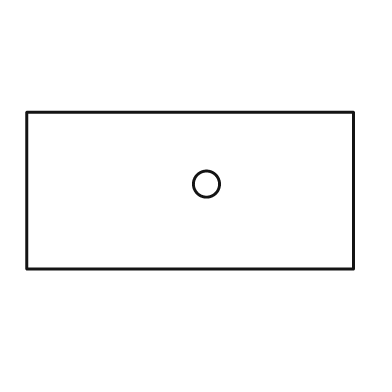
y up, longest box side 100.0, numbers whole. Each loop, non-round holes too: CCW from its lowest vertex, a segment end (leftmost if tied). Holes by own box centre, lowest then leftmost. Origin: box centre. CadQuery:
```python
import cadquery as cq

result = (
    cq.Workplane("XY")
    .moveTo(-50.0, -24.0)
    .lineTo(50.0, -24.0)
    .lineTo(50.0, 24.0)
    .lineTo(-50.0, 24.0)
    .close()
    .moveTo(5.0, 2.0)
    .circle(4.0)
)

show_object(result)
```